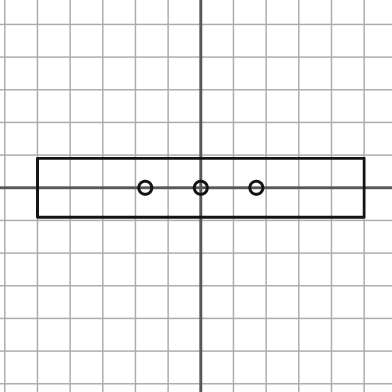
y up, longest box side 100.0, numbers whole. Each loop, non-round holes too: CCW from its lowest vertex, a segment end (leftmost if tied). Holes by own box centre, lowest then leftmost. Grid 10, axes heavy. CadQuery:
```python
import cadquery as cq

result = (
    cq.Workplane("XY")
    .moveTo(-50.0, -9.0)
    .lineTo(50.0, -9.0)
    .lineTo(50.0, 9.0)
    .lineTo(-50.0, 9.0)
    .close()
    .moveTo(-17.0, 0.0)
    .circle(2.0)
    .moveTo(0.0, 0.0)
    .circle(2.0)
    .moveTo(17.0, 0.0)
    .circle(2.0)
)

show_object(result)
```